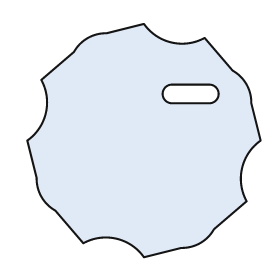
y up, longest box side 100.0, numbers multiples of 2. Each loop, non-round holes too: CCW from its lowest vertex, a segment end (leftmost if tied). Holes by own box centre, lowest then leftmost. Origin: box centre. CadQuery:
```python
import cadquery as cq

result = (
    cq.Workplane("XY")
    .moveTo(0.0, -50.0)
    .lineTo(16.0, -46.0)
    .threePointArc((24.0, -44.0), (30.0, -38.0))
    .lineTo(44.0, -26.0)
    .threePointArc((42.0, -12.0), (50.0, 0.0))
    .lineTo(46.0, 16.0)
    .threePointArc((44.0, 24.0), (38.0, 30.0))
    .lineTo(26.0, 44.0)
    .threePointArc((12.0, 42.0), (0.0, 50.0))
    .lineTo(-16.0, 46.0)
    .threePointArc((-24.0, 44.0), (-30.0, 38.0))
    .lineTo(-44.0, 26.0)
    .threePointArc((-42.0, 12.0), (-50.0, 0.0))
    .lineTo(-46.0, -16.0)
    .threePointArc((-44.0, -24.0), (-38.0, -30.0))
    .lineTo(-26.0, -44.0)
    .threePointArc((-12.0, -42.0), (0.0, -50.0))
    .close()
    .moveTo(12.0, 16.0)
    .lineTo(28.0, 16.0)
    .threePointArc((32.0, 20.0), (28.0, 24.0))
    .lineTo(12.0, 24.0)
    .threePointArc((8.0, 20.0), (12.0, 16.0))
    .close()
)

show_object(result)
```